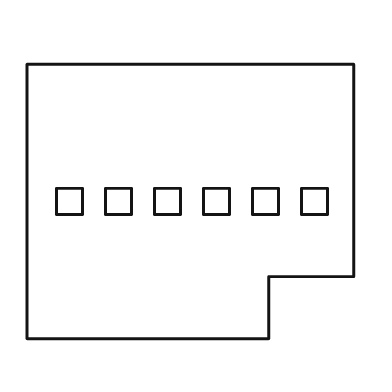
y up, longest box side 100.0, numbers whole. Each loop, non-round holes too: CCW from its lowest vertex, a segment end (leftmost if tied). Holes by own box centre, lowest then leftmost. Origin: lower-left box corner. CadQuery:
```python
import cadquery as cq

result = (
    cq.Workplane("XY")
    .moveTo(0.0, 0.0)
    .lineTo(74.0, 0.0)
    .lineTo(74.0, 19.0)
    .lineTo(100.0, 19.0)
    .lineTo(100.0, 84.0)
    .lineTo(0.0, 84.0)
    .close()
    .moveTo(9.0, 38.0)
    .lineTo(17.0, 38.0)
    .lineTo(17.0, 46.0)
    .lineTo(9.0, 46.0)
    .close()
    .moveTo(24.0, 38.0)
    .lineTo(32.0, 38.0)
    .lineTo(32.0, 46.0)
    .lineTo(24.0, 46.0)
    .close()
    .moveTo(39.0, 38.0)
    .lineTo(47.0, 38.0)
    .lineTo(47.0, 46.0)
    .lineTo(39.0, 46.0)
    .close()
    .moveTo(54.0, 38.0)
    .lineTo(62.0, 38.0)
    .lineTo(62.0, 46.0)
    .lineTo(54.0, 46.0)
    .close()
    .moveTo(69.0, 38.0)
    .lineTo(77.0, 38.0)
    .lineTo(77.0, 46.0)
    .lineTo(69.0, 46.0)
    .close()
    .moveTo(84.0, 38.0)
    .lineTo(92.0, 38.0)
    .lineTo(92.0, 46.0)
    .lineTo(84.0, 46.0)
    .close()
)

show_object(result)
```